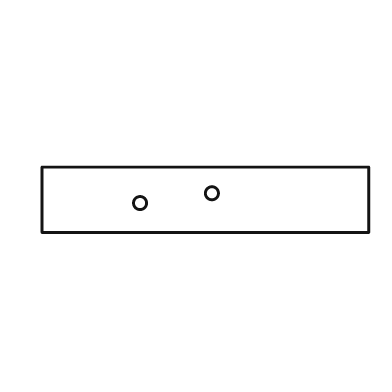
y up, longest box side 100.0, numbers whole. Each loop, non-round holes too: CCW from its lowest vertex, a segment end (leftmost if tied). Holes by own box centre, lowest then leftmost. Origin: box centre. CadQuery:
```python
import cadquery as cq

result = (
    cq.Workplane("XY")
    .moveTo(-50.0, -10.0)
    .lineTo(50.0, -10.0)
    .lineTo(50.0, 10.0)
    .lineTo(-50.0, 10.0)
    .close()
    .moveTo(-20.0, -1.0)
    .circle(2.0)
    .moveTo(2.0, 2.0)
    .circle(2.0)
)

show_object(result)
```